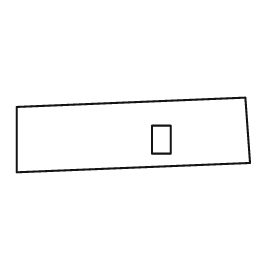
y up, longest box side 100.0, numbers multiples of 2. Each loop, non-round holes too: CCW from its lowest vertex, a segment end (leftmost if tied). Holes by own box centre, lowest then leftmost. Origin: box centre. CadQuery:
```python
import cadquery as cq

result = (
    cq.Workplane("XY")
    .moveTo(-50.0, -16.0)
    .lineTo(50.0, -12.0)
    .lineTo(48.0, 16.0)
    .lineTo(-50.0, 12.0)
    .close()
    .moveTo(8.0, -8.0)
    .lineTo(16.0, -8.0)
    .lineTo(16.0, 4.0)
    .lineTo(8.0, 4.0)
    .close()
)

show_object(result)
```